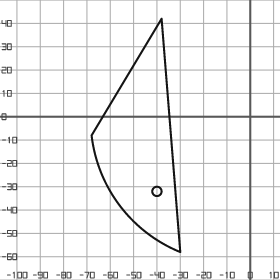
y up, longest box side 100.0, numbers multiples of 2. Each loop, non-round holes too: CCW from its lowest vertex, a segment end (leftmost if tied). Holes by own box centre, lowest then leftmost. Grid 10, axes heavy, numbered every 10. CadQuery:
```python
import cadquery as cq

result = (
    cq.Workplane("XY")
    .moveTo(-30.0, -58.0)
    .lineTo(-38.0, 42.0)
    .lineTo(-68.0, -8.0)
    .threePointArc((-56.0, -38.0), (-30.0, -58.0))
    .close()
    .moveTo(-40.0, -32.0)
    .circle(2.0)
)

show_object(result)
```